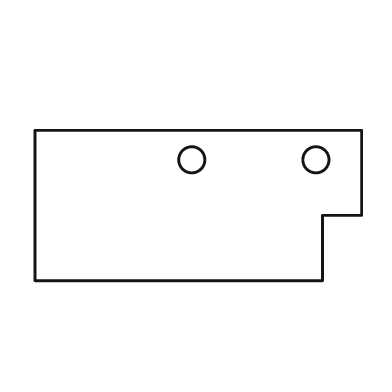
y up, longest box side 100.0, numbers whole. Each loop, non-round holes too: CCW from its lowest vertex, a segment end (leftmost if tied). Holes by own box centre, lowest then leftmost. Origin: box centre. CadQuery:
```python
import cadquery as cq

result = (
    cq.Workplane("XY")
    .moveTo(-50.0, -23.0)
    .lineTo(38.0, -23.0)
    .lineTo(38.0, -3.0)
    .lineTo(50.0, -3.0)
    .lineTo(50.0, 23.0)
    .lineTo(-50.0, 23.0)
    .close()
    .moveTo(-2.0, 14.0)
    .circle(4.0)
    .moveTo(36.0, 14.0)
    .circle(4.0)
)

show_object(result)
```